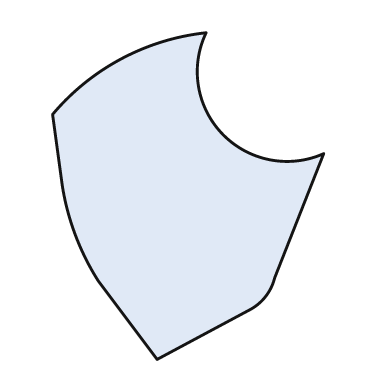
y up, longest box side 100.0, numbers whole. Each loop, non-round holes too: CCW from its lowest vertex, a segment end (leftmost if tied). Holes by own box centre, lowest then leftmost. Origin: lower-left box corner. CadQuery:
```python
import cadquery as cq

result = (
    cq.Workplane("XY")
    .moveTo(32.0, 0.0)
    .lineTo(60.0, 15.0)
    .threePointArc((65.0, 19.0), (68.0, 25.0))
    .lineTo(83.0, 63.0)
    .threePointArc((52.0, 69.0), (47.0, 100.0))
    .threePointArc((21.0, 92.0), (0.0, 75.0))
    .lineTo(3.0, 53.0)
    .threePointArc((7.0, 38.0), (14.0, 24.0))
    .close()
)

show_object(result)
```